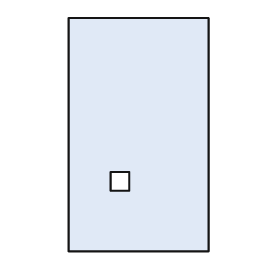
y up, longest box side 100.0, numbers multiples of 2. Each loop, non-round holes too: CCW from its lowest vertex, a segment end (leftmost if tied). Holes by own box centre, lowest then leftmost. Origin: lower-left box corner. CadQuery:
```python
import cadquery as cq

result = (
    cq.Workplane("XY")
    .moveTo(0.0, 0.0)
    .lineTo(60.0, 0.0)
    .lineTo(60.0, 100.0)
    .lineTo(0.0, 100.0)
    .close()
    .moveTo(18.0, 26.0)
    .lineTo(26.0, 26.0)
    .lineTo(26.0, 34.0)
    .lineTo(18.0, 34.0)
    .close()
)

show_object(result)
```